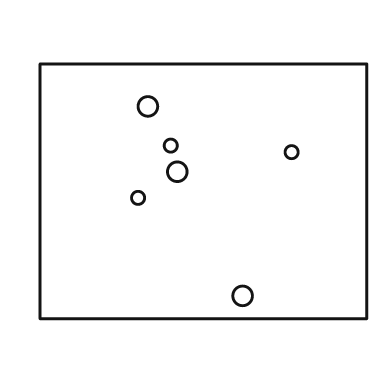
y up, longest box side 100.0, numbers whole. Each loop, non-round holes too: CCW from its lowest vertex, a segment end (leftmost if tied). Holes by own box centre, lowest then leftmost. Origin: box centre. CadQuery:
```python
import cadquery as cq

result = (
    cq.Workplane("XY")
    .moveTo(-50.0, -39.0)
    .lineTo(50.0, -39.0)
    .lineTo(50.0, 39.0)
    .lineTo(-50.0, 39.0)
    .close()
    .moveTo(12.0, -32.0)
    .circle(3.0)
    .moveTo(-20.0, -2.0)
    .circle(2.0)
    .moveTo(-8.0, 6.0)
    .circle(3.0)
    .moveTo(27.0, 12.0)
    .circle(2.0)
    .moveTo(-10.0, 14.0)
    .circle(2.0)
    .moveTo(-17.0, 26.0)
    .circle(3.0)
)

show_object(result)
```